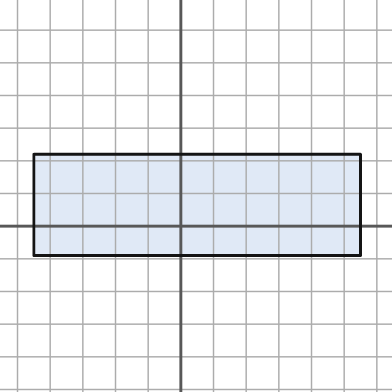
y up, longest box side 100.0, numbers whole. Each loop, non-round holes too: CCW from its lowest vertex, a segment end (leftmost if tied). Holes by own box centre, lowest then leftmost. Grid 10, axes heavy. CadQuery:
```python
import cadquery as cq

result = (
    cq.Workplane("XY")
    .moveTo(-45.0, -9.0)
    .lineTo(55.0, -9.0)
    .lineTo(55.0, 22.0)
    .lineTo(-45.0, 22.0)
    .close()
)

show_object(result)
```